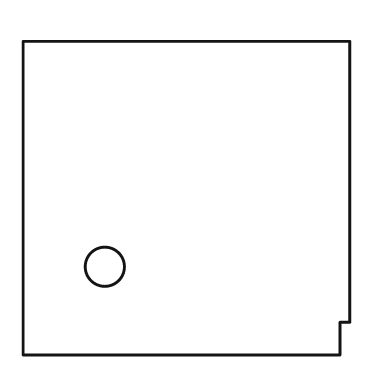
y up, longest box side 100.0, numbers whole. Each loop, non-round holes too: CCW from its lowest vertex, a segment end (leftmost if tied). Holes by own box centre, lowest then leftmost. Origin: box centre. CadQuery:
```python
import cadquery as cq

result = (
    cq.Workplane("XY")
    .moveTo(-50.0, -48.0)
    .lineTo(47.0, -48.0)
    .lineTo(47.0, -38.0)
    .lineTo(50.0, -38.0)
    .lineTo(50.0, 48.0)
    .lineTo(-50.0, 48.0)
    .close()
    .moveTo(-25.0, -21.0)
    .circle(6.0)
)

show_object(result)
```